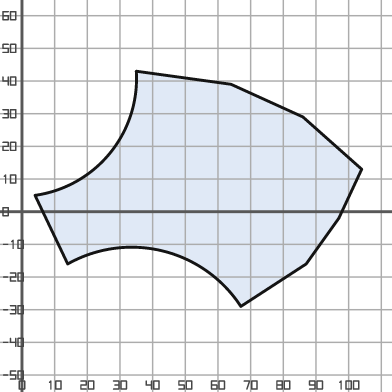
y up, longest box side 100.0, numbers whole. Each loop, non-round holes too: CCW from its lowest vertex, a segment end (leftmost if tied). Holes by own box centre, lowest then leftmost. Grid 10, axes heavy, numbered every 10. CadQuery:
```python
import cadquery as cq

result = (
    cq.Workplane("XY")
    .moveTo(67.0, -29.0)
    .lineTo(87.0, -16.0)
    .lineTo(97.0, -2.0)
    .lineTo(104.0, 13.0)
    .lineTo(86.0, 29.0)
    .lineTo(64.0, 39.0)
    .lineTo(35.0, 43.0)
    .threePointArc((27.0, 18.0), (4.0, 5.0))
    .lineTo(14.0, -16.0)
    .threePointArc((43.0, -12.0), (67.0, -29.0))
    .close()
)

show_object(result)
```